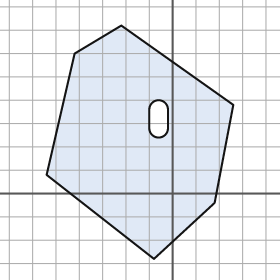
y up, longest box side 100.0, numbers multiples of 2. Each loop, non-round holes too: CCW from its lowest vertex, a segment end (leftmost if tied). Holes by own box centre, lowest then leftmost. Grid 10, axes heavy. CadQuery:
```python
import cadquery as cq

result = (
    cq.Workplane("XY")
    .moveTo(-8.0, -28.0)
    .lineTo(18.0, -4.0)
    .lineTo(26.0, 38.0)
    .lineTo(-22.0, 72.0)
    .lineTo(-42.0, 60.0)
    .lineTo(-54.0, 8.0)
    .close()
    .moveTo(-10.0, 28.0)
    .threePointArc((-6.0, 24.0), (-2.0, 28.0))
    .lineTo(-2.0, 36.0)
    .threePointArc((-6.0, 40.0), (-10.0, 36.0))
    .close()
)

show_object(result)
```